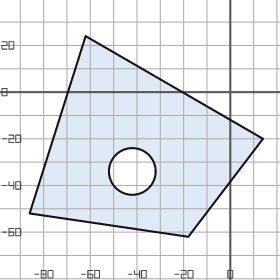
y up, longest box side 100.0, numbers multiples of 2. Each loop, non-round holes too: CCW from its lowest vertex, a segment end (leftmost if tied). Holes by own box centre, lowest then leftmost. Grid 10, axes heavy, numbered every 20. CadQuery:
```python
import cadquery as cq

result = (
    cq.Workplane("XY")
    .moveTo(-18.0, -62.0)
    .lineTo(14.0, -20.0)
    .lineTo(-62.0, 24.0)
    .lineTo(-86.0, -52.0)
    .close()
    .moveTo(-42.0, -34.0)
    .circle(10.0)
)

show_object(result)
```